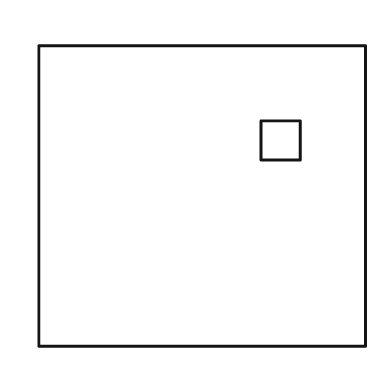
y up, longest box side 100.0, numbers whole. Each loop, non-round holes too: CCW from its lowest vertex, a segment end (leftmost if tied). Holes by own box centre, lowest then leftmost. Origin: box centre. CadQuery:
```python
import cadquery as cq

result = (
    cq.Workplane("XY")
    .moveTo(-50.0, -46.0)
    .lineTo(50.0, -46.0)
    .lineTo(50.0, 46.0)
    .lineTo(-50.0, 46.0)
    .close()
    .moveTo(18.0, 11.0)
    .lineTo(30.0, 11.0)
    .lineTo(30.0, 23.0)
    .lineTo(18.0, 23.0)
    .close()
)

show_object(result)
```